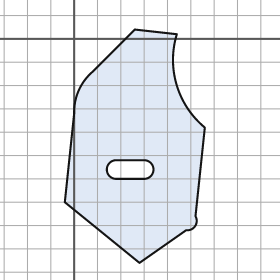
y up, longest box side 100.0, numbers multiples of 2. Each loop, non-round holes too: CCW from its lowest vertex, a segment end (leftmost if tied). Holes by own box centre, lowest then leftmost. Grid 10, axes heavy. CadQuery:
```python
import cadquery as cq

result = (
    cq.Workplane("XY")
    .moveTo(28.0, -96.0)
    .lineTo(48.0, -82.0)
    .threePointArc((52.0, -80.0), (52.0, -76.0))
    .lineTo(56.0, -38.0)
    .threePointArc((44.0, -20.0), (44.0, 2.0))
    .lineTo(26.0, 4.0)
    .lineTo(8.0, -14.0)
    .threePointArc((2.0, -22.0), (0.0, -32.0))
    .lineTo(-4.0, -70.0)
    .close()
    .moveTo(18.0, -60.0)
    .lineTo(30.0, -60.0)
    .threePointArc((34.0, -56.0), (30.0, -52.0))
    .lineTo(18.0, -52.0)
    .threePointArc((14.0, -56.0), (18.0, -60.0))
    .close()
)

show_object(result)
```